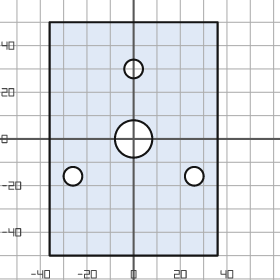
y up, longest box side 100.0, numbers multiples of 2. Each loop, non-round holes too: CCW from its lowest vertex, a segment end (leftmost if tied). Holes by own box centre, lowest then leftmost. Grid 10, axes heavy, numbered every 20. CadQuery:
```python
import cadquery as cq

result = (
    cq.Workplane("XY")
    .moveTo(-36.0, -50.0)
    .lineTo(36.0, -50.0)
    .lineTo(36.0, 50.0)
    .lineTo(-36.0, 50.0)
    .close()
    .moveTo(-26.0, -16.0)
    .circle(4.0)
    .moveTo(26.0, -16.0)
    .circle(4.0)
    .moveTo(0.0, 0.0)
    .circle(8.0)
    .moveTo(0.0, 30.0)
    .circle(4.0)
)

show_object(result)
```